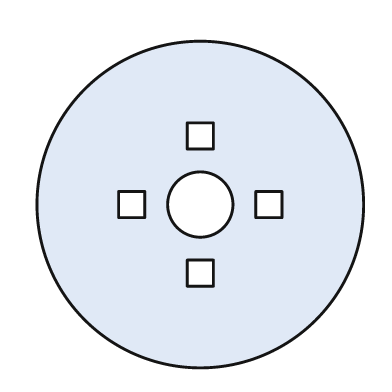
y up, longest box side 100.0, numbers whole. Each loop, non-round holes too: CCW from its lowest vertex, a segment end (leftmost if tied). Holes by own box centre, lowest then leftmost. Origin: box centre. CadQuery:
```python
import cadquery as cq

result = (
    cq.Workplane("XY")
    .moveTo(0.0, 0.0)
    .circle(50.0)
    .moveTo(-4.0, -25.0)
    .lineTo(4.0, -25.0)
    .lineTo(4.0, -17.0)
    .lineTo(-4.0, -17.0)
    .close()
    .moveTo(-25.0, -4.0)
    .lineTo(-17.0, -4.0)
    .lineTo(-17.0, 4.0)
    .lineTo(-25.0, 4.0)
    .close()
    .moveTo(0.0, 0.0)
    .circle(10.0)
    .moveTo(17.0, -4.0)
    .lineTo(25.0, -4.0)
    .lineTo(25.0, 4.0)
    .lineTo(17.0, 4.0)
    .close()
    .moveTo(-4.0, 17.0)
    .lineTo(4.0, 17.0)
    .lineTo(4.0, 25.0)
    .lineTo(-4.0, 25.0)
    .close()
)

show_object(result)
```